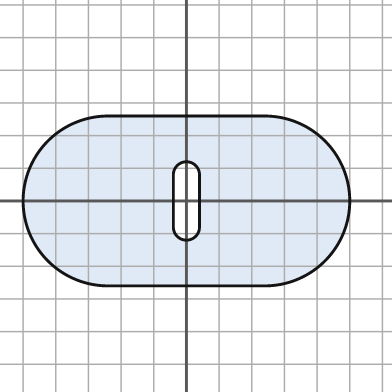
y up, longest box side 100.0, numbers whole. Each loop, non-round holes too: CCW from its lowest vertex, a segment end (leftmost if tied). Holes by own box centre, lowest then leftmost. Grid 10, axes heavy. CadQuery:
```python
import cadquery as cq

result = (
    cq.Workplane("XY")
    .moveTo(-24.0, -26.0)
    .lineTo(24.0, -26.0)
    .threePointArc((50.0, 0.0), (24.0, 26.0))
    .lineTo(-24.0, 26.0)
    .threePointArc((-50.0, 0.0), (-24.0, -26.0))
    .close()
    .moveTo(-4.0, -8.0)
    .threePointArc((0.0, -12.0), (4.0, -8.0))
    .lineTo(4.0, 8.0)
    .threePointArc((0.0, 12.0), (-4.0, 8.0))
    .close()
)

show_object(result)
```